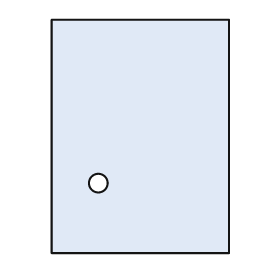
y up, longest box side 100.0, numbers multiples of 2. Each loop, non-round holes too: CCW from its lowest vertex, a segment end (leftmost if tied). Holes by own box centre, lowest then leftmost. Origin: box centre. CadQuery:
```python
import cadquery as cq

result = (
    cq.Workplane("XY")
    .moveTo(-38.0, -50.0)
    .lineTo(38.0, -50.0)
    .lineTo(38.0, 50.0)
    .lineTo(-38.0, 50.0)
    .close()
    .moveTo(-18.0, -20.0)
    .circle(4.0)
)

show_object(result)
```